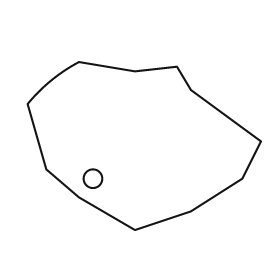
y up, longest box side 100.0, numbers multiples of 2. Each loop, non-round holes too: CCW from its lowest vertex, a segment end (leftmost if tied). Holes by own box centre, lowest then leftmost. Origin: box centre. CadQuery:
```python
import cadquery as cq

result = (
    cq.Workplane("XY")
    .moveTo(-4.0, -36.0)
    .lineTo(20.0, -28.0)
    .lineTo(42.0, -14.0)
    .lineTo(50.0, 2.0)
    .lineTo(20.0, 24.0)
    .lineTo(14.0, 34.0)
    .lineTo(-4.0, 32.0)
    .lineTo(-28.0, 36.0)
    .threePointArc((-40.0, 28.0), (-50.0, 18.0))
    .lineTo(-42.0, -10.0)
    .lineTo(-28.0, -22.0)
    .close()
    .moveTo(-22.0, -14.0)
    .circle(4.0)
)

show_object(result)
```